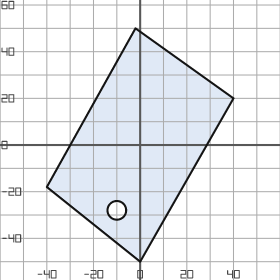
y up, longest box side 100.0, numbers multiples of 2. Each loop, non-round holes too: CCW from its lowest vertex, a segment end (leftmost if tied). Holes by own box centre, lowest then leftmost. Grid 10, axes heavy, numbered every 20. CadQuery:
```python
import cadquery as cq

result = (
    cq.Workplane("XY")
    .moveTo(0.0, -50.0)
    .lineTo(40.0, 20.0)
    .lineTo(-2.0, 50.0)
    .lineTo(-40.0, -18.0)
    .close()
    .moveTo(-10.0, -28.0)
    .circle(4.0)
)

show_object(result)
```